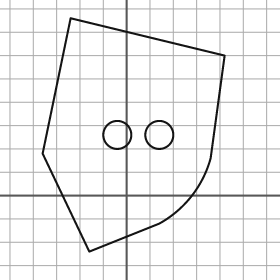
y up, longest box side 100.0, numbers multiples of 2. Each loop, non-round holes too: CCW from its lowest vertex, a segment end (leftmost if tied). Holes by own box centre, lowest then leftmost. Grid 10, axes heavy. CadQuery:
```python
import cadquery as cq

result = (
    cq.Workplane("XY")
    .moveTo(-16.0, -24.0)
    .lineTo(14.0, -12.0)
    .threePointArc((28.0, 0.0), (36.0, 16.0))
    .lineTo(42.0, 60.0)
    .lineTo(-24.0, 76.0)
    .lineTo(-36.0, 18.0)
    .close()
    .moveTo(-4.0, 26.0)
    .circle(6.0)
    .moveTo(14.0, 26.0)
    .circle(6.0)
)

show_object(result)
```